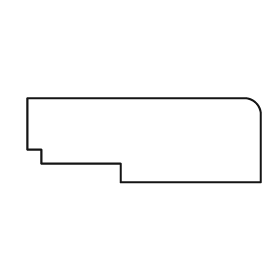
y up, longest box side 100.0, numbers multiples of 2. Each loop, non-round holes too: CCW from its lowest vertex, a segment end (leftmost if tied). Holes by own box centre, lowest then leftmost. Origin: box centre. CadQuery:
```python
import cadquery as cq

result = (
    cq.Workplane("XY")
    .moveTo(-10.0, -18.0)
    .lineTo(50.0, -18.0)
    .lineTo(50.0, 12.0)
    .threePointArc((48.0, 16.0), (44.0, 18.0))
    .lineTo(-50.0, 18.0)
    .lineTo(-50.0, -4.0)
    .lineTo(-44.0, -4.0)
    .lineTo(-44.0, -10.0)
    .lineTo(-10.0, -10.0)
    .close()
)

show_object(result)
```